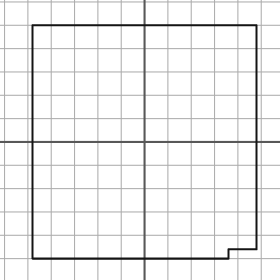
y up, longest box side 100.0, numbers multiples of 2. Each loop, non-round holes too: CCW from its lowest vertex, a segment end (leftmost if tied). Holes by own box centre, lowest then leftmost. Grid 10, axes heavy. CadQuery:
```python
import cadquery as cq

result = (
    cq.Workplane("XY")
    .moveTo(-48.0, -50.0)
    .lineTo(36.0, -50.0)
    .lineTo(36.0, -46.0)
    .lineTo(48.0, -46.0)
    .lineTo(48.0, 50.0)
    .lineTo(-48.0, 50.0)
    .close()
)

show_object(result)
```